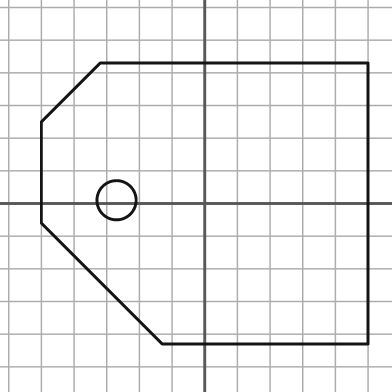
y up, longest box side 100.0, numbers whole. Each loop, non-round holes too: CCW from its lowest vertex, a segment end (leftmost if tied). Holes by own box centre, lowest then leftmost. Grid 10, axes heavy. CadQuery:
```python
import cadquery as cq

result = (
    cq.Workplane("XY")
    .moveTo(-13.0, -43.0)
    .lineTo(50.0, -43.0)
    .lineTo(50.0, 43.0)
    .lineTo(-32.0, 43.0)
    .lineTo(-50.0, 25.0)
    .lineTo(-50.0, -6.0)
    .close()
    .moveTo(-27.0, 1.0)
    .circle(6.0)
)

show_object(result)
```